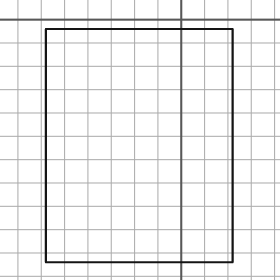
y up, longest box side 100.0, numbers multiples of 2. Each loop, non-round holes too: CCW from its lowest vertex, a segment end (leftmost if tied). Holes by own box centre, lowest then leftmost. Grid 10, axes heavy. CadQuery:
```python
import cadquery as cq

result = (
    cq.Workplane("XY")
    .moveTo(-58.0, -104.0)
    .lineTo(22.0, -104.0)
    .lineTo(22.0, -4.0)
    .lineTo(-58.0, -4.0)
    .close()
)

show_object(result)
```